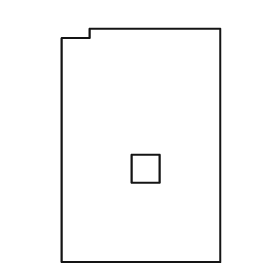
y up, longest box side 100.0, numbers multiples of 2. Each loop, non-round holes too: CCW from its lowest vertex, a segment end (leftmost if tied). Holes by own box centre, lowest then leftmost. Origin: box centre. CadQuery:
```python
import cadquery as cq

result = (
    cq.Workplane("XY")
    .moveTo(-34.0, -50.0)
    .lineTo(34.0, -50.0)
    .lineTo(34.0, 50.0)
    .lineTo(-22.0, 50.0)
    .lineTo(-22.0, 46.0)
    .lineTo(-34.0, 46.0)
    .close()
    .moveTo(-4.0, -16.0)
    .lineTo(8.0, -16.0)
    .lineTo(8.0, -4.0)
    .lineTo(-4.0, -4.0)
    .close()
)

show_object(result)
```